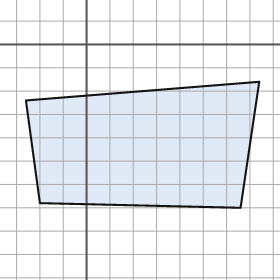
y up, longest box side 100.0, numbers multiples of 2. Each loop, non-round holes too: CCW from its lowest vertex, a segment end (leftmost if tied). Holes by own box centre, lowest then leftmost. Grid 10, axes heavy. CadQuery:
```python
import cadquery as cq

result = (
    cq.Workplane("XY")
    .moveTo(66.0, -70.0)
    .lineTo(74.0, -16.0)
    .lineTo(-26.0, -24.0)
    .lineTo(-20.0, -68.0)
    .close()
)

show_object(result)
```